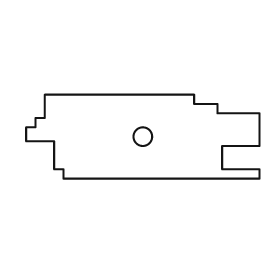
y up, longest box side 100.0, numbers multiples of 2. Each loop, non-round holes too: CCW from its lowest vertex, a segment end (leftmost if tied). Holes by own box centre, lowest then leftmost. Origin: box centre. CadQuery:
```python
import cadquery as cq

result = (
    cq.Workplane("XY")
    .moveTo(-34.0, -18.0)
    .lineTo(50.0, -18.0)
    .lineTo(50.0, -14.0)
    .lineTo(34.0, -14.0)
    .lineTo(34.0, -4.0)
    .lineTo(50.0, -4.0)
    .lineTo(50.0, 10.0)
    .lineTo(32.0, 10.0)
    .lineTo(32.0, 14.0)
    .lineTo(22.0, 14.0)
    .lineTo(22.0, 18.0)
    .lineTo(-42.0, 18.0)
    .lineTo(-42.0, 8.0)
    .lineTo(-46.0, 8.0)
    .lineTo(-46.0, 4.0)
    .lineTo(-50.0, 4.0)
    .lineTo(-50.0, -2.0)
    .lineTo(-38.0, -2.0)
    .lineTo(-38.0, -14.0)
    .lineTo(-34.0, -14.0)
    .close()
    .moveTo(0.0, 0.0)
    .circle(4.0)
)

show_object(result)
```